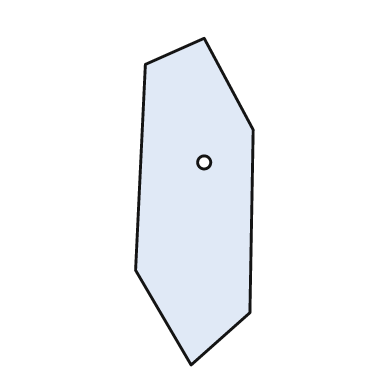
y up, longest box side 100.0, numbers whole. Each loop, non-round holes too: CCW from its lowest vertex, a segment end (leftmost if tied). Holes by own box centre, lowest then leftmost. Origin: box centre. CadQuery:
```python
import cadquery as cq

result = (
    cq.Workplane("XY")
    .moveTo(-1.0, -50.0)
    .lineTo(17.0, -34.0)
    .lineTo(18.0, 22.0)
    .lineTo(3.0, 50.0)
    .lineTo(-15.0, 42.0)
    .lineTo(-18.0, -21.0)
    .close()
    .moveTo(3.0, 12.0)
    .circle(2.0)
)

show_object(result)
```